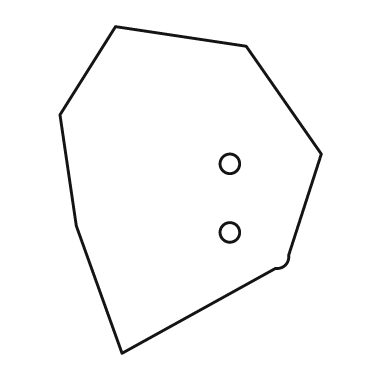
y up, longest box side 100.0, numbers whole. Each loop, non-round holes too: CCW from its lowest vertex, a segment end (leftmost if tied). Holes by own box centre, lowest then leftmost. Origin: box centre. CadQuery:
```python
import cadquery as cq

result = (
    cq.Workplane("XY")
    .moveTo(-21.0, -50.0)
    .lineTo(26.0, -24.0)
    .threePointArc((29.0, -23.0), (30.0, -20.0))
    .lineTo(40.0, 11.0)
    .lineTo(17.0, 44.0)
    .lineTo(-23.0, 50.0)
    .lineTo(-40.0, 23.0)
    .lineTo(-35.0, -11.0)
    .close()
    .moveTo(12.0, -13.0)
    .circle(3.0)
    .moveTo(12.0, 8.0)
    .circle(3.0)
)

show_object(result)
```